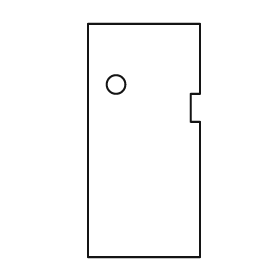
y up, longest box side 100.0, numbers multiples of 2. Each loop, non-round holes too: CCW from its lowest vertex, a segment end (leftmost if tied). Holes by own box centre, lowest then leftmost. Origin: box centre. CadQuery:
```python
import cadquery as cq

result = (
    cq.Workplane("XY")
    .moveTo(-24.0, -50.0)
    .lineTo(24.0, -50.0)
    .lineTo(24.0, 8.0)
    .lineTo(20.0, 8.0)
    .lineTo(20.0, 20.0)
    .lineTo(24.0, 20.0)
    .lineTo(24.0, 50.0)
    .lineTo(-24.0, 50.0)
    .close()
    .moveTo(-12.0, 24.0)
    .circle(4.0)
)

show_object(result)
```